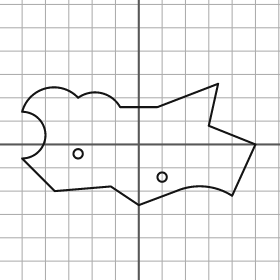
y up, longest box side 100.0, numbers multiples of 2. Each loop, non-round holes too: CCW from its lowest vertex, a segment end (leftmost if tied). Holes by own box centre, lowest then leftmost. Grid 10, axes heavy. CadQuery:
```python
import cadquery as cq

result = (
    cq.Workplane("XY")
    .moveTo(0.0, -26.0)
    .lineTo(16.0, -20.0)
    .threePointArc((28.0, -18.0), (40.0, -22.0))
    .lineTo(50.0, 0.0)
    .lineTo(30.0, 8.0)
    .lineTo(34.0, 26.0)
    .lineTo(8.0, 16.0)
    .lineTo(-8.0, 16.0)
    .threePointArc((-16.0, 22.0), (-26.0, 20.0))
    .threePointArc((-40.0, 24.0), (-50.0, 14.0))
    .threePointArc((-40.0, 4.0), (-50.0, -6.0))
    .lineTo(-36.0, -20.0)
    .lineTo(-12.0, -18.0)
    .close()
    .moveTo(10.0, -14.0)
    .circle(2.0)
    .moveTo(-26.0, -4.0)
    .circle(2.0)
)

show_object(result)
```